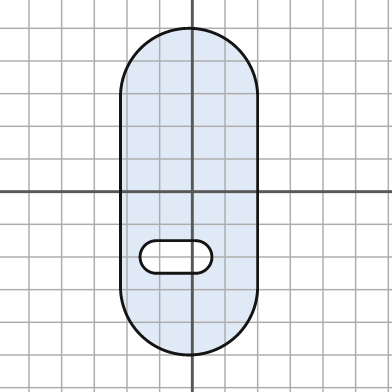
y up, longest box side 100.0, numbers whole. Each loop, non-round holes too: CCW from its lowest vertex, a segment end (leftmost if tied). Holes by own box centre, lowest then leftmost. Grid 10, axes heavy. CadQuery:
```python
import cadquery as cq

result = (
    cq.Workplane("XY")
    .moveTo(-22.0, -29.0)
    .threePointArc((-1.0, -50.0), (20.0, -29.0))
    .lineTo(20.0, 29.0)
    .threePointArc((-1.0, 50.0), (-22.0, 29.0))
    .close()
    .moveTo(-11.0, -25.0)
    .lineTo(1.0, -25.0)
    .threePointArc((6.0, -20.0), (1.0, -15.0))
    .lineTo(-11.0, -15.0)
    .threePointArc((-16.0, -20.0), (-11.0, -25.0))
    .close()
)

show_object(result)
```